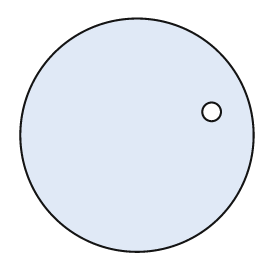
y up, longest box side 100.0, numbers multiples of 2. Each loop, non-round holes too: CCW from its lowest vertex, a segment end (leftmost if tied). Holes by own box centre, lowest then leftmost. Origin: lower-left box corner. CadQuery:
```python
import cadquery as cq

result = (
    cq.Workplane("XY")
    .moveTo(50.0, 50.0)
    .circle(50.0)
    .moveTo(82.0, 60.0)
    .circle(4.0)
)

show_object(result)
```